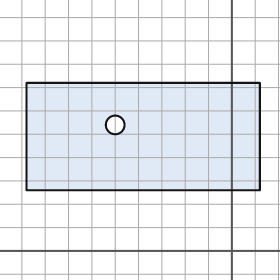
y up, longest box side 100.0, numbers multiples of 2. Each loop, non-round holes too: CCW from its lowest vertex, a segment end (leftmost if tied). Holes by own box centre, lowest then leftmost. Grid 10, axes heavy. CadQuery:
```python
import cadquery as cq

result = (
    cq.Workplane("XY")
    .moveTo(-88.0, 26.0)
    .lineTo(12.0, 26.0)
    .lineTo(12.0, 72.0)
    .lineTo(-88.0, 72.0)
    .close()
    .moveTo(-50.0, 54.0)
    .circle(4.0)
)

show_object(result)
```